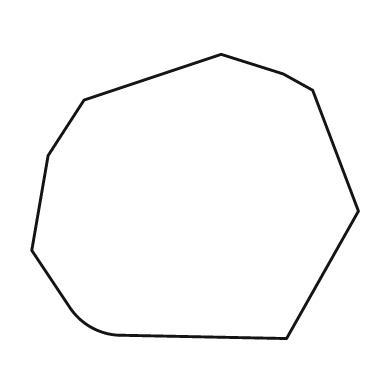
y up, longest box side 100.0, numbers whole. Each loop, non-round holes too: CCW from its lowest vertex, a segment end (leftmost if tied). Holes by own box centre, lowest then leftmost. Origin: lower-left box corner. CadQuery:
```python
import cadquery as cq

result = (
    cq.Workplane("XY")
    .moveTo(78.0, 0.0)
    .lineTo(100.0, 39.0)
    .lineTo(86.0, 76.0)
    .lineTo(77.0, 81.0)
    .lineTo(58.0, 87.0)
    .lineTo(16.0, 73.0)
    .lineTo(5.0, 56.0)
    .lineTo(0.0, 27.0)
    .lineTo(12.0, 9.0)
    .threePointArc((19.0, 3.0), (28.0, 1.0))
    .close()
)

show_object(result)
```